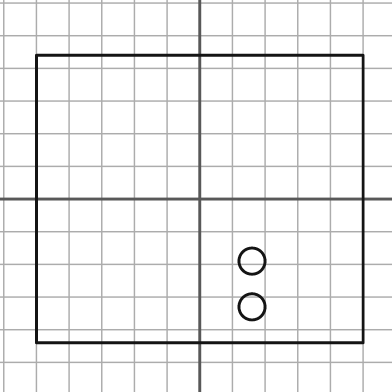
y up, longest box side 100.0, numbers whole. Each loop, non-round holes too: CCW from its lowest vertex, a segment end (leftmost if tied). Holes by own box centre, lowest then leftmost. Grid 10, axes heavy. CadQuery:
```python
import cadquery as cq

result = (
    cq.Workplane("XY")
    .moveTo(-50.0, -44.0)
    .lineTo(50.0, -44.0)
    .lineTo(50.0, 44.0)
    .lineTo(-50.0, 44.0)
    .close()
    .moveTo(16.0, -33.0)
    .circle(4.0)
    .moveTo(16.0, -19.0)
    .circle(4.0)
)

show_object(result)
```